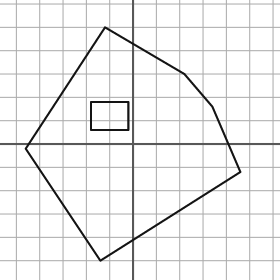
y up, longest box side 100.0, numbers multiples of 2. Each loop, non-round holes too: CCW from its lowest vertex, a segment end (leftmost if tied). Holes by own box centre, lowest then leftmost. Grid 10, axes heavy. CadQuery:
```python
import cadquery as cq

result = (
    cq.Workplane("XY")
    .moveTo(-14.0, -50.0)
    .lineTo(46.0, -12.0)
    .lineTo(34.0, 16.0)
    .lineTo(22.0, 30.0)
    .lineTo(-12.0, 50.0)
    .lineTo(-46.0, -2.0)
    .close()
    .moveTo(-18.0, 6.0)
    .lineTo(-2.0, 6.0)
    .lineTo(-2.0, 18.0)
    .lineTo(-18.0, 18.0)
    .close()
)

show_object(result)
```